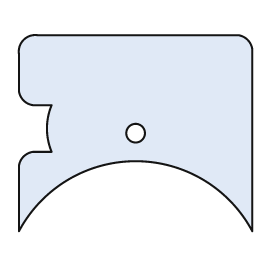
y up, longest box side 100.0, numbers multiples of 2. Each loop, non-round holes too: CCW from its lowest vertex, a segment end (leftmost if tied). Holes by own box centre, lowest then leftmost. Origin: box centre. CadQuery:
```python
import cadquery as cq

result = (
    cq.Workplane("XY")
    .moveTo(-50.0, -42.0)
    .threePointArc((0.0, -12.0), (50.0, -42.0))
    .lineTo(50.0, 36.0)
    .threePointArc((48.0, 40.0), (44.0, 42.0))
    .lineTo(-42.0, 42.0)
    .threePointArc((-48.0, 40.0), (-50.0, 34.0))
    .lineTo(-50.0, 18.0)
    .threePointArc((-48.0, 14.0), (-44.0, 12.0))
    .lineTo(-36.0, 12.0)
    .threePointArc((-38.0, 2.0), (-36.0, -8.0))
    .lineTo(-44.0, -8.0)
    .threePointArc((-48.0, -10.0), (-50.0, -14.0))
    .close()
    .moveTo(0.0, 0.0)
    .circle(4.0)
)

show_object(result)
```